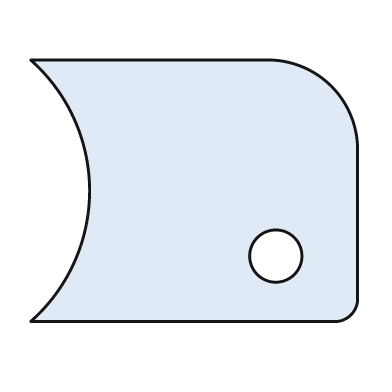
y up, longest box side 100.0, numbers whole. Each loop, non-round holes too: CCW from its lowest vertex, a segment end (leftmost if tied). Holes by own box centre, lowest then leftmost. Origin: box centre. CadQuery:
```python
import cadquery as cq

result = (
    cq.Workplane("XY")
    .moveTo(-50.0, -40.0)
    .lineTo(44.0, -40.0)
    .threePointArc((48.0, -38.0), (50.0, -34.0))
    .lineTo(50.0, 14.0)
    .threePointArc((42.0, 32.0), (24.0, 40.0))
    .lineTo(-50.0, 40.0)
    .threePointArc((-32.0, 0.0), (-50.0, -40.0))
    .close()
    .moveTo(25.0, -20.0)
    .circle(8.0)
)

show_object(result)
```